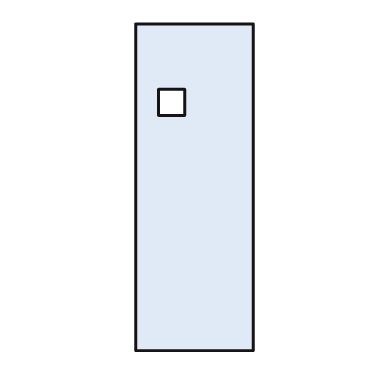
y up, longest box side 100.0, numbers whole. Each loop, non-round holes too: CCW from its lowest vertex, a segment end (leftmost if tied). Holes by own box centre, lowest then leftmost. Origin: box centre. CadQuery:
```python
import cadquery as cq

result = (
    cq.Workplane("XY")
    .moveTo(-18.0, -50.0)
    .lineTo(18.0, -50.0)
    .lineTo(18.0, 50.0)
    .lineTo(-18.0, 50.0)
    .close()
    .moveTo(-11.0, 22.0)
    .lineTo(-3.0, 22.0)
    .lineTo(-3.0, 30.0)
    .lineTo(-11.0, 30.0)
    .close()
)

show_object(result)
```